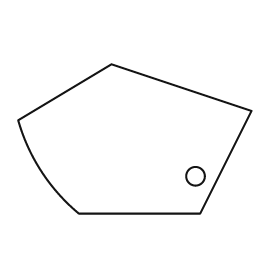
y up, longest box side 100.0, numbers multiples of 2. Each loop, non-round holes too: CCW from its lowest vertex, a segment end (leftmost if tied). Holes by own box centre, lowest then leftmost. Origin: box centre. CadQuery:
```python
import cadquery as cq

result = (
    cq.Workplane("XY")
    .moveTo(-24.0, -32.0)
    .lineTo(28.0, -32.0)
    .lineTo(50.0, 12.0)
    .lineTo(-10.0, 32.0)
    .lineTo(-50.0, 8.0)
    .threePointArc((-40.0, -14.0), (-24.0, -32.0))
    .close()
    .moveTo(26.0, -16.0)
    .circle(4.0)
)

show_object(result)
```